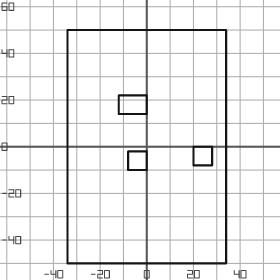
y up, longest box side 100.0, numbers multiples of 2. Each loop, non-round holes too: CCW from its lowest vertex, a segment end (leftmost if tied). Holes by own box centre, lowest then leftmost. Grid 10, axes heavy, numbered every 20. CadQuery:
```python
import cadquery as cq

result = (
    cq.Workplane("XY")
    .moveTo(-34.0, -50.0)
    .lineTo(34.0, -50.0)
    .lineTo(34.0, 50.0)
    .lineTo(-34.0, 50.0)
    .close()
    .moveTo(-8.0, -10.0)
    .lineTo(0.0, -10.0)
    .lineTo(0.0, -2.0)
    .lineTo(-8.0, -2.0)
    .close()
    .moveTo(20.0, -8.0)
    .lineTo(28.0, -8.0)
    .lineTo(28.0, 0.0)
    .lineTo(20.0, 0.0)
    .close()
    .moveTo(-12.0, 14.0)
    .lineTo(0.0, 14.0)
    .lineTo(0.0, 22.0)
    .lineTo(-12.0, 22.0)
    .close()
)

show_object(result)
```